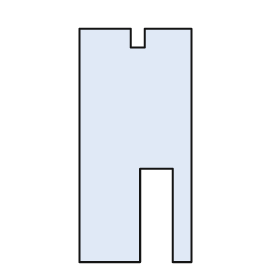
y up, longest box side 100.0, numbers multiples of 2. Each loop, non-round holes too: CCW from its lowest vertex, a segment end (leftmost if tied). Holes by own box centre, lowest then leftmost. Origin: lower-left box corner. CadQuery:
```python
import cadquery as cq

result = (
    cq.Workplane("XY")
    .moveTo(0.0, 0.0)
    .lineTo(26.0, 0.0)
    .lineTo(26.0, 40.0)
    .lineTo(40.0, 40.0)
    .lineTo(40.0, 0.0)
    .lineTo(48.0, 0.0)
    .lineTo(48.0, 100.0)
    .lineTo(28.0, 100.0)
    .lineTo(28.0, 92.0)
    .lineTo(22.0, 92.0)
    .lineTo(22.0, 100.0)
    .lineTo(0.0, 100.0)
    .close()
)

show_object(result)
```